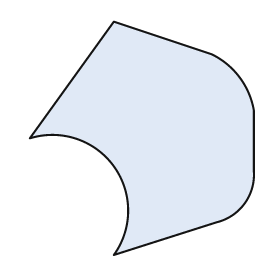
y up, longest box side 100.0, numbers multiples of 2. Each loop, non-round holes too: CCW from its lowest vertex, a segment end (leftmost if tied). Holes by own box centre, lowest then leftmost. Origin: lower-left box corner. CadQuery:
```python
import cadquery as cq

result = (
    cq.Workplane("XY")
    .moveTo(36.0, 0.0)
    .lineTo(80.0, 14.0)
    .threePointArc((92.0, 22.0), (96.0, 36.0))
    .lineTo(96.0, 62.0)
    .threePointArc((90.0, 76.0), (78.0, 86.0))
    .lineTo(36.0, 100.0)
    .lineTo(0.0, 50.0)
    .threePointArc((36.0, 38.0), (36.0, 0.0))
    .close()
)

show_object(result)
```